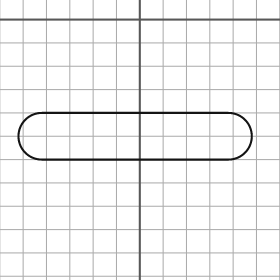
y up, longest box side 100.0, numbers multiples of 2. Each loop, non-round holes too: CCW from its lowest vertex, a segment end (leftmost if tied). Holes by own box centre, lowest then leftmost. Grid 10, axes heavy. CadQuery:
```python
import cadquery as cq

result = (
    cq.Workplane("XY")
    .moveTo(-42.0, -60.0)
    .lineTo(38.0, -60.0)
    .threePointArc((48.0, -50.0), (38.0, -40.0))
    .lineTo(-42.0, -40.0)
    .threePointArc((-52.0, -50.0), (-42.0, -60.0))
    .close()
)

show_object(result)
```